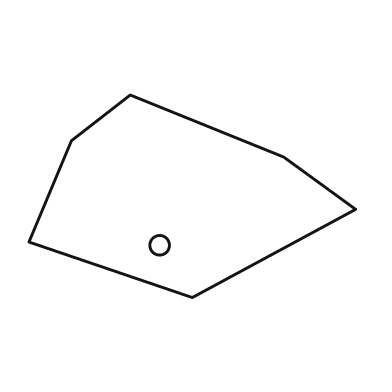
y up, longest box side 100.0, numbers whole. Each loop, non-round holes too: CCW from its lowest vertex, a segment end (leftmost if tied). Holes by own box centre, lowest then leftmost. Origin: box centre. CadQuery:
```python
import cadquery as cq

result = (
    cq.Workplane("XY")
    .moveTo(0.0, -31.0)
    .lineTo(50.0, -4.0)
    .lineTo(28.0, 12.0)
    .lineTo(-19.0, 31.0)
    .lineTo(-37.0, 17.0)
    .lineTo(-50.0, -14.0)
    .close()
    .moveTo(-10.0, -15.0)
    .circle(3.0)
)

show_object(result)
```